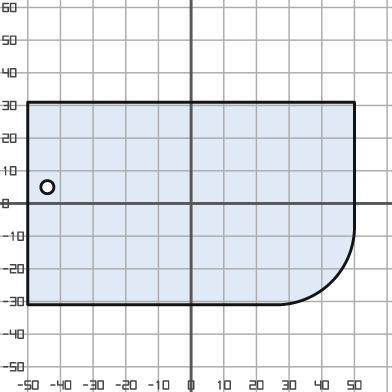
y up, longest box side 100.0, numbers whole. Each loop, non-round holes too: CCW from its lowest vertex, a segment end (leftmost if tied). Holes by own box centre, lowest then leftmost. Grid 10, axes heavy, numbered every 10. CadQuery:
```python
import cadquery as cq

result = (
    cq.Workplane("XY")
    .moveTo(-50.0, -31.0)
    .lineTo(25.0, -31.0)
    .threePointArc((43.0, -24.0), (50.0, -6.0))
    .lineTo(50.0, 31.0)
    .lineTo(-50.0, 31.0)
    .close()
    .moveTo(-44.0, 5.0)
    .circle(2.0)
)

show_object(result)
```